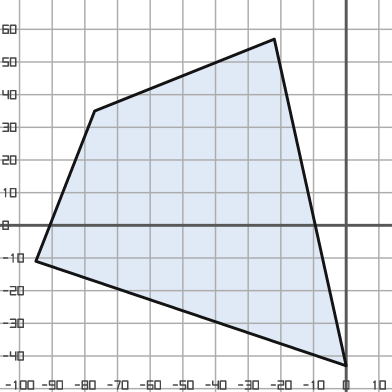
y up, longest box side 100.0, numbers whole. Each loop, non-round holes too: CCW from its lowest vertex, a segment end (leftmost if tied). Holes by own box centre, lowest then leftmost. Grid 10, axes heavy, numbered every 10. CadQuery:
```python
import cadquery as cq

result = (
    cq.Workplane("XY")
    .moveTo(0.0, -43.0)
    .lineTo(-22.0, 57.0)
    .lineTo(-77.0, 35.0)
    .lineTo(-95.0, -11.0)
    .close()
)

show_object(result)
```